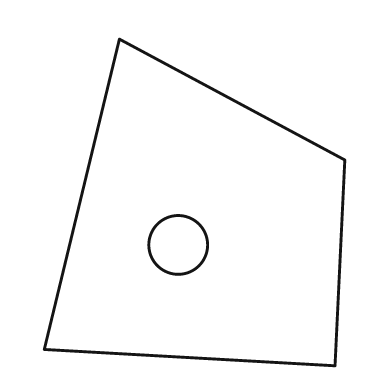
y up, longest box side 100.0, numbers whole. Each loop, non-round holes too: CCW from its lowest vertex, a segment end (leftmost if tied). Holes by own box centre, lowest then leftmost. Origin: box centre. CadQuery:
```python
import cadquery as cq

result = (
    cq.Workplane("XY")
    .moveTo(43.0, -50.0)
    .lineTo(46.0, 13.0)
    .lineTo(-23.0, 50.0)
    .lineTo(-46.0, -45.0)
    .close()
    .moveTo(-5.0, -13.0)
    .circle(9.0)
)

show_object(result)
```